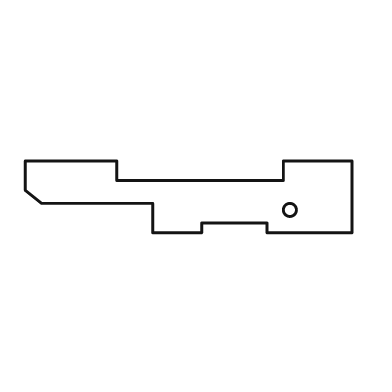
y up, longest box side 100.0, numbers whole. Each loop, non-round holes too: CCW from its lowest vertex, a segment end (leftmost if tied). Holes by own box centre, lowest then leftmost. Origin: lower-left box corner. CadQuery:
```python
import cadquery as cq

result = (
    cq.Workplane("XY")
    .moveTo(39.0, 0.0)
    .lineTo(54.0, 0.0)
    .lineTo(54.0, 3.0)
    .lineTo(74.0, 3.0)
    .lineTo(74.0, 0.0)
    .lineTo(100.0, 0.0)
    .lineTo(100.0, 22.0)
    .lineTo(79.0, 22.0)
    .lineTo(79.0, 16.0)
    .lineTo(28.0, 16.0)
    .lineTo(28.0, 22.0)
    .lineTo(0.0, 22.0)
    .lineTo(0.0, 13.0)
    .lineTo(5.0, 9.0)
    .lineTo(39.0, 9.0)
    .close()
    .moveTo(81.0, 7.0)
    .circle(2.0)
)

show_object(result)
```